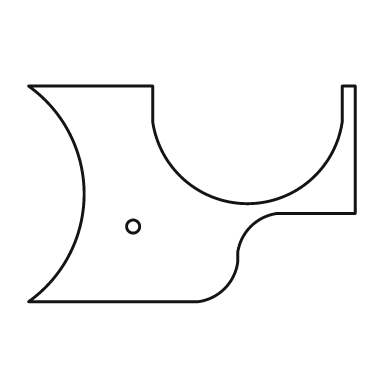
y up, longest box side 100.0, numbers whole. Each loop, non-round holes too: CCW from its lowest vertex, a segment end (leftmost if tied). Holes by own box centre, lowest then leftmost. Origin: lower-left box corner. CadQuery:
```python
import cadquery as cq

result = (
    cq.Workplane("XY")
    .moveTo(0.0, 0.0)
    .lineTo(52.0, 0.0)
    .threePointArc((60.0, 4.0), (64.0, 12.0))
    .lineTo(64.0, 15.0)
    .threePointArc((68.0, 23.0), (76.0, 27.0))
    .lineTo(100.0, 27.0)
    .lineTo(100.0, 66.0)
    .lineTo(96.0, 66.0)
    .lineTo(96.0, 55.0)
    .threePointArc((67.0, 30.0), (38.0, 55.0))
    .lineTo(38.0, 66.0)
    .lineTo(0.0, 66.0)
    .threePointArc((17.0, 33.0), (0.0, 0.0))
    .close()
    .moveTo(32.0, 23.0)
    .circle(2.0)
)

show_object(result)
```